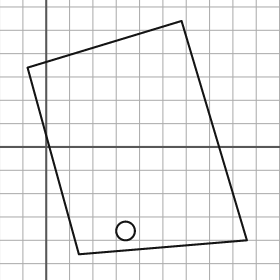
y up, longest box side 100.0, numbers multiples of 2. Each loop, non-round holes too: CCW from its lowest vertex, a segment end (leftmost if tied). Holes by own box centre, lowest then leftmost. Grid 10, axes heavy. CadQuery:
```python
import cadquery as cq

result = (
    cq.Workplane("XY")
    .moveTo(14.0, -46.0)
    .lineTo(86.0, -40.0)
    .lineTo(58.0, 54.0)
    .lineTo(-8.0, 34.0)
    .close()
    .moveTo(34.0, -36.0)
    .circle(4.0)
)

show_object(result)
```